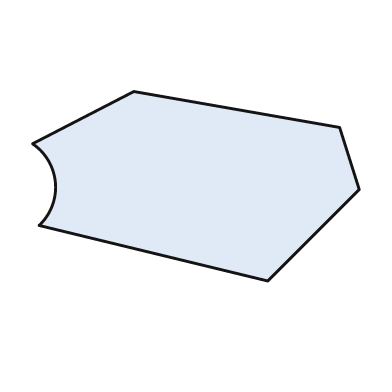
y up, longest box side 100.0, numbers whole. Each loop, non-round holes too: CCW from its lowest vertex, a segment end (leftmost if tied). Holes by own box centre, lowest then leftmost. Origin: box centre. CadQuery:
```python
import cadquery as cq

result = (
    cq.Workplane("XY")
    .moveTo(22.0, -29.0)
    .lineTo(50.0, -1.0)
    .lineTo(44.0, 18.0)
    .lineTo(-19.0, 29.0)
    .lineTo(-50.0, 13.0)
    .threePointArc((-43.0, 1.0), (-48.0, -12.0))
    .close()
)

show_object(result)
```